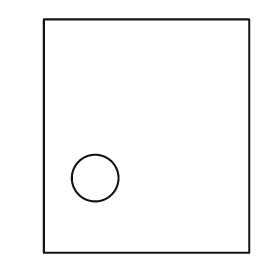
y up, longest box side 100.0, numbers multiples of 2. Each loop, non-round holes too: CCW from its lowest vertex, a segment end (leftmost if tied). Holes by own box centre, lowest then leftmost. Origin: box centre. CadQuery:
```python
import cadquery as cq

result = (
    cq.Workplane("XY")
    .moveTo(-44.0, -50.0)
    .lineTo(44.0, -50.0)
    .lineTo(44.0, 50.0)
    .lineTo(-44.0, 50.0)
    .close()
    .moveTo(-22.0, -18.0)
    .circle(10.0)
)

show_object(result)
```